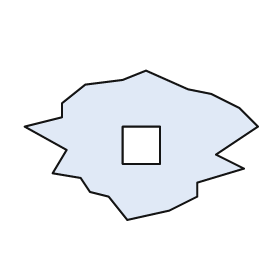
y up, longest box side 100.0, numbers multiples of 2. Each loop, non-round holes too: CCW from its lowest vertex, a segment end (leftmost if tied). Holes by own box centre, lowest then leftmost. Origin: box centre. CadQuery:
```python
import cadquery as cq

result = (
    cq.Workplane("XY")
    .moveTo(-6.0, -32.0)
    .lineTo(12.0, -28.0)
    .lineTo(24.0, -22.0)
    .lineTo(24.0, -16.0)
    .lineTo(44.0, -10.0)
    .lineTo(32.0, -4.0)
    .lineTo(50.0, 8.0)
    .lineTo(42.0, 16.0)
    .lineTo(30.0, 22.0)
    .lineTo(20.0, 24.0)
    .lineTo(2.0, 32.0)
    .lineTo(-8.0, 28.0)
    .lineTo(-24.0, 26.0)
    .lineTo(-34.0, 18.0)
    .lineTo(-34.0, 12.0)
    .lineTo(-50.0, 8.0)
    .lineTo(-32.0, -2.0)
    .lineTo(-38.0, -12.0)
    .lineTo(-26.0, -14.0)
    .lineTo(-22.0, -20.0)
    .lineTo(-14.0, -22.0)
    .close()
    .moveTo(-8.0, -8.0)
    .lineTo(8.0, -8.0)
    .lineTo(8.0, 8.0)
    .lineTo(-8.0, 8.0)
    .close()
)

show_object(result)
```